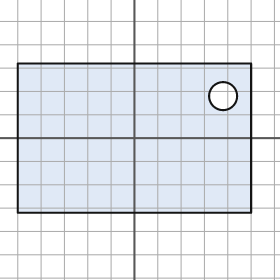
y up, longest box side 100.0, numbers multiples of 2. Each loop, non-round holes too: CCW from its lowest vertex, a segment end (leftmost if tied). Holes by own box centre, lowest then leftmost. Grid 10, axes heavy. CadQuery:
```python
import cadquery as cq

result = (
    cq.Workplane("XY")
    .moveTo(-50.0, -32.0)
    .lineTo(50.0, -32.0)
    .lineTo(50.0, 32.0)
    .lineTo(-50.0, 32.0)
    .close()
    .moveTo(38.0, 18.0)
    .circle(6.0)
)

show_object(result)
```